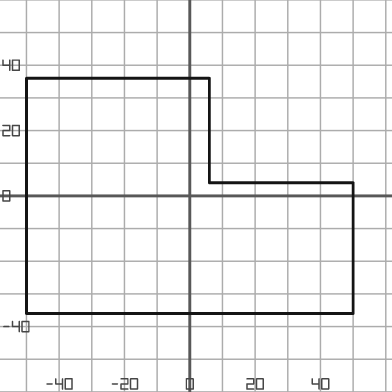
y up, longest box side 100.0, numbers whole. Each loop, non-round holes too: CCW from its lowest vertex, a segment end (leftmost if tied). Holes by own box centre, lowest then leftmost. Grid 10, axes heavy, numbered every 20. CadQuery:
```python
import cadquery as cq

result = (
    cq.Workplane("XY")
    .moveTo(-50.0, -36.0)
    .lineTo(50.0, -36.0)
    .lineTo(50.0, 4.0)
    .lineTo(6.0, 4.0)
    .lineTo(6.0, 36.0)
    .lineTo(-50.0, 36.0)
    .close()
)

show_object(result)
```